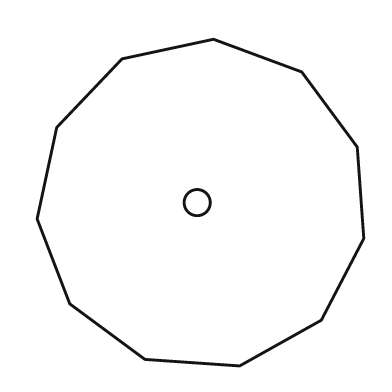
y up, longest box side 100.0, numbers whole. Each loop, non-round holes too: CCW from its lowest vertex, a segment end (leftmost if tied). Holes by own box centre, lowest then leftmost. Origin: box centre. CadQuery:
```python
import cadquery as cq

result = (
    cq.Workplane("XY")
    .moveTo(12.0, -50.0)
    .lineTo(37.0, -36.0)
    .lineTo(50.0, -11.0)
    .lineTo(48.0, 17.0)
    .lineTo(31.0, 40.0)
    .lineTo(4.0, 50.0)
    .lineTo(-24.0, 44.0)
    .lineTo(-44.0, 23.0)
    .lineTo(-50.0, -5.0)
    .lineTo(-40.0, -31.0)
    .lineTo(-17.0, -48.0)
    .close()
    .moveTo(-1.0, 0.0)
    .circle(4.0)
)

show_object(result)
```